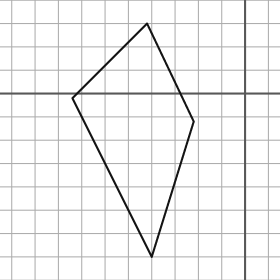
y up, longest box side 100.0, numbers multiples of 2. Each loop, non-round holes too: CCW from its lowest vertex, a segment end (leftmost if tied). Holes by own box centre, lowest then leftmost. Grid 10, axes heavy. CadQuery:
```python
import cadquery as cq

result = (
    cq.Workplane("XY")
    .moveTo(-40.0, -70.0)
    .lineTo(-22.0, -12.0)
    .lineTo(-42.0, 30.0)
    .lineTo(-74.0, -2.0)
    .close()
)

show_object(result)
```